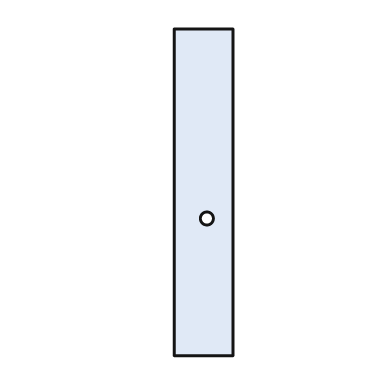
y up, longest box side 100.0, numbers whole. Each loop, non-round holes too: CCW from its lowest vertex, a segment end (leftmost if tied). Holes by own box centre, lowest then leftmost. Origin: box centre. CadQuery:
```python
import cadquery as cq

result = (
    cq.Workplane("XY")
    .moveTo(-9.0, -50.0)
    .lineTo(9.0, -50.0)
    .lineTo(9.0, 50.0)
    .lineTo(-9.0, 50.0)
    .close()
    .moveTo(1.0, -8.0)
    .circle(2.0)
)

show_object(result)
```